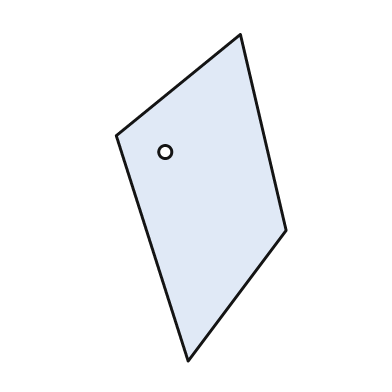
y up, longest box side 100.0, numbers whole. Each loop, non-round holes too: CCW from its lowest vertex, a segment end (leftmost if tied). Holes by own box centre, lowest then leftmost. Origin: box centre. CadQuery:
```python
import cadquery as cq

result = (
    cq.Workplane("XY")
    .moveTo(-4.0, -50.0)
    .lineTo(26.0, -10.0)
    .lineTo(12.0, 50.0)
    .lineTo(-26.0, 19.0)
    .close()
    .moveTo(-11.0, 14.0)
    .circle(2.0)
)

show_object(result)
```